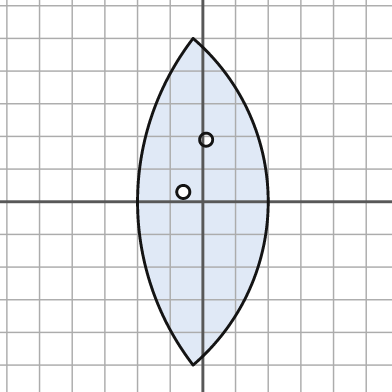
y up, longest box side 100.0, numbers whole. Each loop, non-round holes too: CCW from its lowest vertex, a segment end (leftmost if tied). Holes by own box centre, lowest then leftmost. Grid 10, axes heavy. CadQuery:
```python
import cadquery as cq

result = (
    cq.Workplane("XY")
    .moveTo(-3.0, -50.0)
    .threePointArc((20.0, 0.0), (-3.0, 50.0))
    .threePointArc((-20.0, 0.0), (-3.0, -50.0))
    .close()
    .moveTo(-6.0, 3.0)
    .circle(2.0)
    .moveTo(1.0, 19.0)
    .circle(2.0)
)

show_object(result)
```